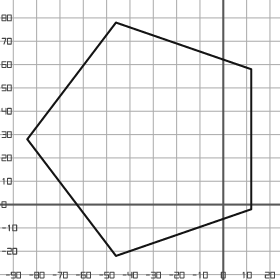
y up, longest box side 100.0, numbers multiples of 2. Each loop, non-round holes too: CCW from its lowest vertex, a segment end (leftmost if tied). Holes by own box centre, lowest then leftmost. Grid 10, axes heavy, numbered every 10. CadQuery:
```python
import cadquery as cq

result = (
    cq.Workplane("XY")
    .moveTo(-46.0, -22.0)
    .lineTo(12.0, -2.0)
    .lineTo(12.0, 58.0)
    .lineTo(-46.0, 78.0)
    .lineTo(-84.0, 28.0)
    .close()
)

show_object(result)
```